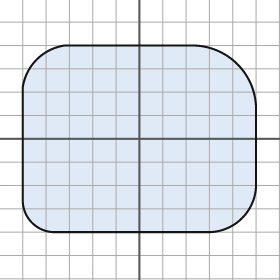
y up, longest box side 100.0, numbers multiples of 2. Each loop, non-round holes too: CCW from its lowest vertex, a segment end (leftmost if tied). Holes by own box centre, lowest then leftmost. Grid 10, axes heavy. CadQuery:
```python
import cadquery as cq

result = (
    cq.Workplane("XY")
    .moveTo(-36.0, -40.0)
    .lineTo(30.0, -40.0)
    .threePointArc((44.0, -34.0), (50.0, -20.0))
    .lineTo(50.0, 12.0)
    .threePointArc((42.0, 32.0), (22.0, 40.0))
    .lineTo(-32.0, 40.0)
    .threePointArc((-44.0, 34.0), (-50.0, 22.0))
    .lineTo(-50.0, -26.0)
    .threePointArc((-46.0, -36.0), (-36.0, -40.0))
    .close()
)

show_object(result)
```